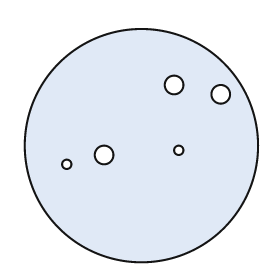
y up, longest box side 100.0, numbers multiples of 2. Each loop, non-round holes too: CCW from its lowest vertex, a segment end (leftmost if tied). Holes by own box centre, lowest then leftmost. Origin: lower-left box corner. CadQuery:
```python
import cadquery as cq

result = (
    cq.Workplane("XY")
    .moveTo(50.0, 50.0)
    .circle(50.0)
    .moveTo(18.0, 42.0)
    .circle(2.0)
    .moveTo(34.0, 46.0)
    .circle(4.0)
    .moveTo(66.0, 48.0)
    .circle(2.0)
    .moveTo(84.0, 72.0)
    .circle(4.0)
    .moveTo(64.0, 76.0)
    .circle(4.0)
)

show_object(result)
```